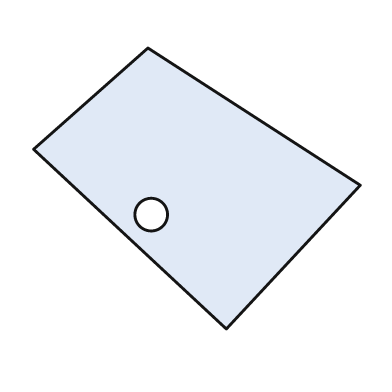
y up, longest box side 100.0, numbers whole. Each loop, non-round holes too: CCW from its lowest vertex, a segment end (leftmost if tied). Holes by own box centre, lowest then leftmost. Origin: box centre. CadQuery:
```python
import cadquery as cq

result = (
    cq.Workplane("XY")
    .moveTo(9.0, -43.0)
    .lineTo(50.0, 1.0)
    .lineTo(-15.0, 43.0)
    .lineTo(-50.0, 12.0)
    .close()
    .moveTo(-14.0, -8.0)
    .circle(5.0)
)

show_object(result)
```